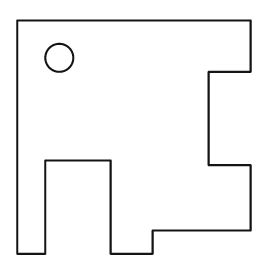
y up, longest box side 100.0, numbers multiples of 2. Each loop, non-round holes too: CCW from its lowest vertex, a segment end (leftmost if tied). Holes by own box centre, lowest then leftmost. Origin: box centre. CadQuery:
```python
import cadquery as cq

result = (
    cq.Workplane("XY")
    .moveTo(-50.0, -50.0)
    .lineTo(-38.0, -50.0)
    .lineTo(-38.0, -10.0)
    .lineTo(-10.0, -10.0)
    .lineTo(-10.0, -50.0)
    .lineTo(8.0, -50.0)
    .lineTo(8.0, -40.0)
    .lineTo(50.0, -40.0)
    .lineTo(50.0, -12.0)
    .lineTo(32.0, -12.0)
    .lineTo(32.0, 28.0)
    .lineTo(50.0, 28.0)
    .lineTo(50.0, 50.0)
    .lineTo(-50.0, 50.0)
    .close()
    .moveTo(-32.0, 34.0)
    .circle(6.0)
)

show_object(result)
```